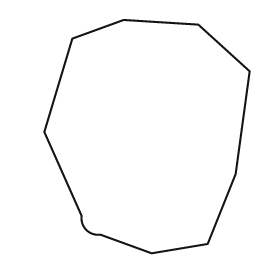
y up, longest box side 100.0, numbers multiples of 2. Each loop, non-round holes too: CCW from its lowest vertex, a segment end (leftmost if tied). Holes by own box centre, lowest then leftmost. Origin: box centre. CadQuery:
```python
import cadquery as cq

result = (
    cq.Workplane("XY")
    .moveTo(2.0, -50.0)
    .lineTo(26.0, -46.0)
    .lineTo(38.0, -16.0)
    .lineTo(44.0, 28.0)
    .lineTo(22.0, 48.0)
    .lineTo(-10.0, 50.0)
    .lineTo(-32.0, 42.0)
    .lineTo(-44.0, 2.0)
    .lineTo(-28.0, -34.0)
    .threePointArc((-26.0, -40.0), (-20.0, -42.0))
    .close()
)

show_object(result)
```